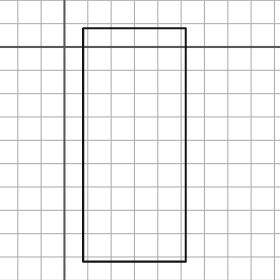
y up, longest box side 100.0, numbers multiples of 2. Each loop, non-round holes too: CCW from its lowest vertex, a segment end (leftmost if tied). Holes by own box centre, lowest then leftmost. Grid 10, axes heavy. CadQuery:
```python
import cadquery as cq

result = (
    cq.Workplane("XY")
    .moveTo(8.0, -92.0)
    .lineTo(52.0, -92.0)
    .lineTo(52.0, 8.0)
    .lineTo(8.0, 8.0)
    .close()
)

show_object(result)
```